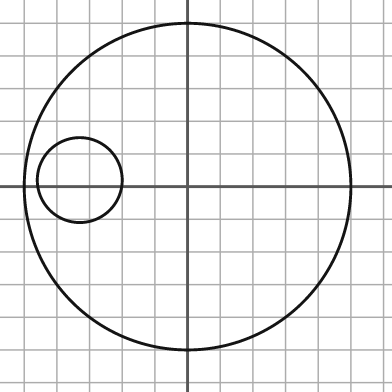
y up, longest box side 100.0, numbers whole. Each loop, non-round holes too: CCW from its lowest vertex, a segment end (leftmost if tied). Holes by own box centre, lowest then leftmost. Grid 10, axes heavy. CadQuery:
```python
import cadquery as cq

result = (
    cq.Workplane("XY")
    .moveTo(0.0, 0.0)
    .circle(50.0)
    .moveTo(-33.0, 2.0)
    .circle(13.0)
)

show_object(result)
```